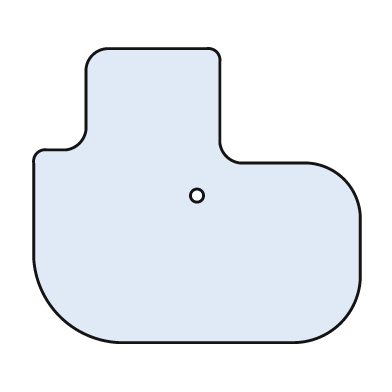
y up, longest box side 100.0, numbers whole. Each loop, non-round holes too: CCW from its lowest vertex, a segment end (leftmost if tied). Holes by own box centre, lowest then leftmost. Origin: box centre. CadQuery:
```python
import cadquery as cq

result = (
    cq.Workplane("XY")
    .moveTo(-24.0, -45.0)
    .lineTo(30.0, -45.0)
    .threePointArc((44.0, -39.0), (50.0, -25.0))
    .lineTo(50.0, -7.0)
    .threePointArc((45.0, 5.0), (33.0, 10.0))
    .lineTo(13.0, 10.0)
    .threePointArc((9.0, 12.0), (7.0, 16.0))
    .lineTo(7.0, 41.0)
    .threePointArc((6.0, 44.0), (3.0, 45.0))
    .lineTo(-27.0, 45.0)
    .threePointArc((-32.0, 43.0), (-34.0, 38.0))
    .lineTo(-34.0, 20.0)
    .threePointArc((-36.0, 16.0), (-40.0, 14.0))
    .lineTo(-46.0, 14.0)
    .threePointArc((-49.0, 13.0), (-50.0, 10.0))
    .lineTo(-50.0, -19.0)
    .threePointArc((-42.0, -37.0), (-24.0, -45.0))
    .close()
    .moveTo(0.0, 0.0)
    .circle(2.0)
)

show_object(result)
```